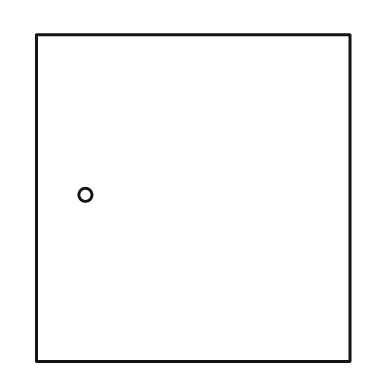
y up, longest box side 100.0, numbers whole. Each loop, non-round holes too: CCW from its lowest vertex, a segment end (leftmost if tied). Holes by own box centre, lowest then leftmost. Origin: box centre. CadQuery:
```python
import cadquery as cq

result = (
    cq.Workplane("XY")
    .moveTo(-48.0, -50.0)
    .lineTo(48.0, -50.0)
    .lineTo(48.0, 50.0)
    .lineTo(-48.0, 50.0)
    .close()
    .moveTo(-33.0, 1.0)
    .circle(2.0)
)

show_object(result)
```